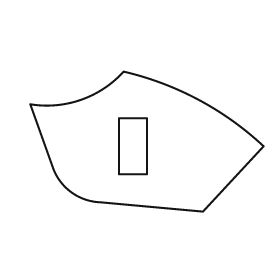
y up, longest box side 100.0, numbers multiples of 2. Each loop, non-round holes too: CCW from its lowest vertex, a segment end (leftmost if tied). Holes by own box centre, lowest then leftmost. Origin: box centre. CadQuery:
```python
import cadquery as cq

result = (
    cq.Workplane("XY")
    .moveTo(24.0, -30.0)
    .lineTo(50.0, -2.0)
    .threePointArc((22.0, 18.0), (-10.0, 30.0))
    .threePointArc((-28.0, 18.0), (-50.0, 16.0))
    .lineTo(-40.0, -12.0)
    .threePointArc((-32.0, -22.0), (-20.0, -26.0))
    .close()
    .moveTo(-12.0, -14.0)
    .lineTo(0.0, -14.0)
    .lineTo(0.0, 10.0)
    .lineTo(-12.0, 10.0)
    .close()
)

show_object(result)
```